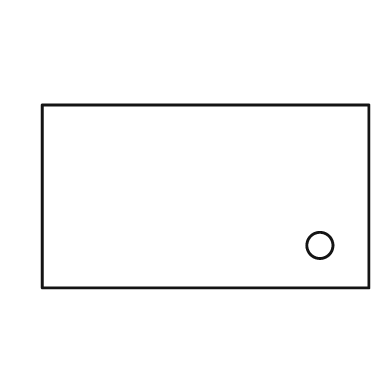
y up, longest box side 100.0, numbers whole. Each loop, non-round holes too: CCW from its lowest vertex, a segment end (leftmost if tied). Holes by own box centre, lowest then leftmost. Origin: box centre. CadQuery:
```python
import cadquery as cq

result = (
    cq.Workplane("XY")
    .moveTo(-50.0, -28.0)
    .lineTo(50.0, -28.0)
    .lineTo(50.0, 28.0)
    .lineTo(-50.0, 28.0)
    .close()
    .moveTo(35.0, -15.0)
    .circle(4.0)
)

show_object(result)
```